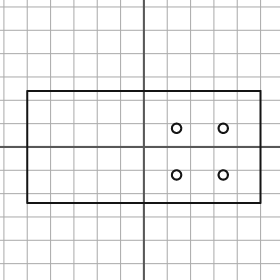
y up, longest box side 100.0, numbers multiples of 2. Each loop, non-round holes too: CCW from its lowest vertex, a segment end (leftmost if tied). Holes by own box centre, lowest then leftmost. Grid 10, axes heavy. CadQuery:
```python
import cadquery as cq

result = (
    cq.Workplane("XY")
    .moveTo(-50.0, -24.0)
    .lineTo(50.0, -24.0)
    .lineTo(50.0, 24.0)
    .lineTo(-50.0, 24.0)
    .close()
    .moveTo(14.0, -12.0)
    .circle(2.0)
    .moveTo(34.0, -12.0)
    .circle(2.0)
    .moveTo(14.0, 8.0)
    .circle(2.0)
    .moveTo(34.0, 8.0)
    .circle(2.0)
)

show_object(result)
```